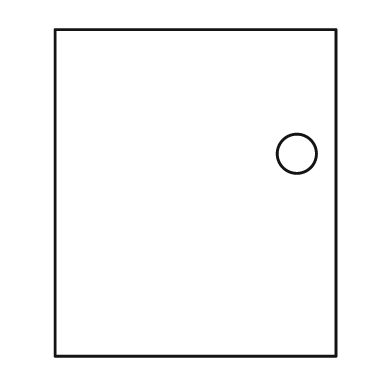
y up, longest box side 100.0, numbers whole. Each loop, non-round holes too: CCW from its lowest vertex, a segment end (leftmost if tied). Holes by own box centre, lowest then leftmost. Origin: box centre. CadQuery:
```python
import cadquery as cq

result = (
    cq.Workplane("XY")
    .moveTo(-43.0, -50.0)
    .lineTo(43.0, -50.0)
    .lineTo(43.0, 50.0)
    .lineTo(-43.0, 50.0)
    .close()
    .moveTo(31.0, 12.0)
    .circle(6.0)
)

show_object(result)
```